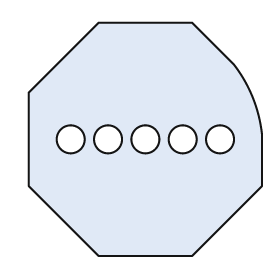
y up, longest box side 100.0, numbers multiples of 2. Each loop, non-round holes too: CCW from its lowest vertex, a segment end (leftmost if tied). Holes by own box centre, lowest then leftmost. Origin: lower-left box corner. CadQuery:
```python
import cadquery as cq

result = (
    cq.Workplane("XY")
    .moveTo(30.0, 0.0)
    .lineTo(70.0, 0.0)
    .lineTo(100.0, 30.0)
    .lineTo(100.0, 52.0)
    .threePointArc((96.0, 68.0), (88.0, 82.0))
    .lineTo(70.0, 100.0)
    .lineTo(30.0, 100.0)
    .lineTo(0.0, 70.0)
    .lineTo(0.0, 30.0)
    .close()
    .moveTo(18.0, 50.0)
    .circle(6.0)
    .moveTo(34.0, 50.0)
    .circle(6.0)
    .moveTo(50.0, 50.0)
    .circle(6.0)
    .moveTo(66.0, 50.0)
    .circle(6.0)
    .moveTo(82.0, 50.0)
    .circle(6.0)
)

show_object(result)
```